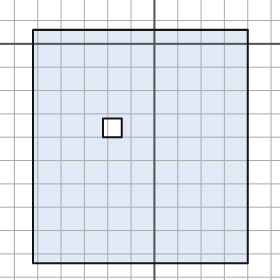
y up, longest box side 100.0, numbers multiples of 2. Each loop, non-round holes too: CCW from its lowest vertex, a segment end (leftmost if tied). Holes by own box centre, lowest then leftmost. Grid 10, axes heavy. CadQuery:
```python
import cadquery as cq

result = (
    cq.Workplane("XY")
    .moveTo(-52.0, -94.0)
    .lineTo(40.0, -94.0)
    .lineTo(40.0, 6.0)
    .lineTo(-52.0, 6.0)
    .close()
    .moveTo(-22.0, -40.0)
    .lineTo(-14.0, -40.0)
    .lineTo(-14.0, -32.0)
    .lineTo(-22.0, -32.0)
    .close()
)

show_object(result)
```